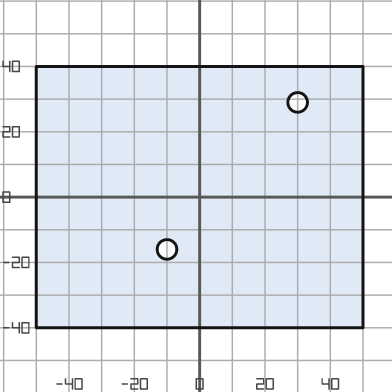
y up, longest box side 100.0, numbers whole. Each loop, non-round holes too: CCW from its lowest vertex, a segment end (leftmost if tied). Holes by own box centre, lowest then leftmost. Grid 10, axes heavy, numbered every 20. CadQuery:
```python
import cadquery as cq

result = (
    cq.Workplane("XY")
    .moveTo(-50.0, -40.0)
    .lineTo(50.0, -40.0)
    .lineTo(50.0, 40.0)
    .lineTo(-50.0, 40.0)
    .close()
    .moveTo(-10.0, -16.0)
    .circle(3.0)
    .moveTo(30.0, 29.0)
    .circle(3.0)
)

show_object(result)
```